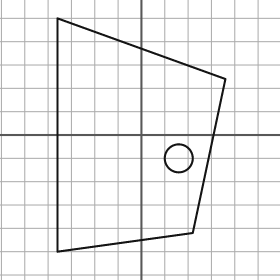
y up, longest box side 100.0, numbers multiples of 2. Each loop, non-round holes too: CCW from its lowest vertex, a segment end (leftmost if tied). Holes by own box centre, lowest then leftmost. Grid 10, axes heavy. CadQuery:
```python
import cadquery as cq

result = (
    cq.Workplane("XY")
    .moveTo(-36.0, -50.0)
    .lineTo(22.0, -42.0)
    .lineTo(36.0, 24.0)
    .lineTo(-36.0, 50.0)
    .close()
    .moveTo(16.0, -10.0)
    .circle(6.0)
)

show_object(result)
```